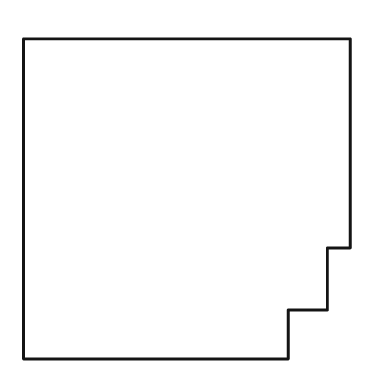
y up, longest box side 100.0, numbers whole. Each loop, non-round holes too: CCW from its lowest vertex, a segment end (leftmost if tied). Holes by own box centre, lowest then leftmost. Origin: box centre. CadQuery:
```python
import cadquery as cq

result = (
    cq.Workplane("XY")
    .moveTo(-50.0, -49.0)
    .lineTo(31.0, -49.0)
    .lineTo(31.0, -34.0)
    .lineTo(43.0, -34.0)
    .lineTo(43.0, -15.0)
    .lineTo(50.0, -15.0)
    .lineTo(50.0, 49.0)
    .lineTo(-50.0, 49.0)
    .close()
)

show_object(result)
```